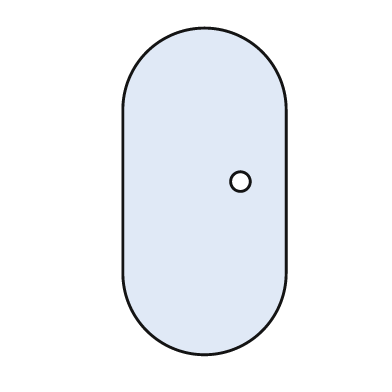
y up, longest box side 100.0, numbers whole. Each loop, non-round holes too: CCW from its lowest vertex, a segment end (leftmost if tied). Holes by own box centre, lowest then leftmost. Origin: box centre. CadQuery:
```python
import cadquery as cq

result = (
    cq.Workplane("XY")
    .moveTo(-25.0, -25.0)
    .threePointArc((0.0, -50.0), (25.0, -25.0))
    .lineTo(25.0, 25.0)
    .threePointArc((0.0, 50.0), (-25.0, 25.0))
    .close()
    .moveTo(11.0, 3.0)
    .circle(3.0)
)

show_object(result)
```